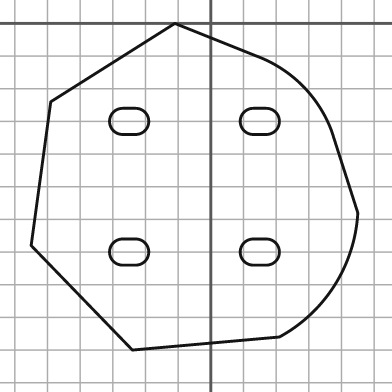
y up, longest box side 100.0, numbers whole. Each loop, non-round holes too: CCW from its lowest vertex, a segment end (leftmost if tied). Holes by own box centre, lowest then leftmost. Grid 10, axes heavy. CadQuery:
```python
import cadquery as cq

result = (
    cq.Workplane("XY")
    .moveTo(-24.0, -100.0)
    .lineTo(21.0, -96.0)
    .threePointArc((38.0, -80.0), (45.0, -58.0))
    .lineTo(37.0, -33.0)
    .threePointArc((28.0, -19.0), (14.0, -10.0))
    .lineTo(-11.0, 0.0)
    .lineTo(-49.0, -24.0)
    .lineTo(-55.0, -68.0)
    .close()
    .moveTo(-27.0, -74.0)
    .lineTo(-23.0, -74.0)
    .threePointArc((-19.0, -70.0), (-23.0, -66.0))
    .lineTo(-27.0, -66.0)
    .threePointArc((-31.0, -70.0), (-27.0, -74.0))
    .close()
    .moveTo(13.0, -74.0)
    .lineTo(17.0, -74.0)
    .threePointArc((21.0, -70.0), (17.0, -66.0))
    .lineTo(13.0, -66.0)
    .threePointArc((9.0, -70.0), (13.0, -74.0))
    .close()
    .moveTo(-27.0, -34.0)
    .lineTo(-23.0, -34.0)
    .threePointArc((-19.0, -30.0), (-23.0, -26.0))
    .lineTo(-27.0, -26.0)
    .threePointArc((-31.0, -30.0), (-27.0, -34.0))
    .close()
    .moveTo(13.0, -34.0)
    .lineTo(17.0, -34.0)
    .threePointArc((21.0, -30.0), (17.0, -26.0))
    .lineTo(13.0, -26.0)
    .threePointArc((9.0, -30.0), (13.0, -34.0))
    .close()
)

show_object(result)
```